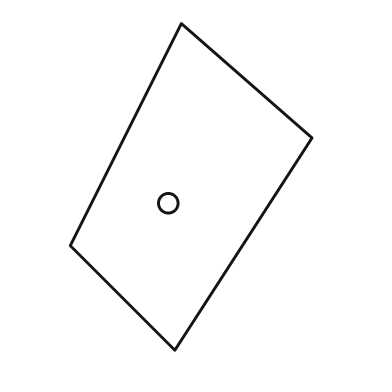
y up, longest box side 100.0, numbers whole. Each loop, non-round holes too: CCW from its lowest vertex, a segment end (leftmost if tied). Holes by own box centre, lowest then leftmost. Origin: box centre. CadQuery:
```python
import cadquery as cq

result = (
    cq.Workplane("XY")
    .moveTo(-5.0, -50.0)
    .lineTo(37.0, 15.0)
    .lineTo(-3.0, 50.0)
    .lineTo(-37.0, -18.0)
    .close()
    .moveTo(-7.0, -5.0)
    .circle(3.0)
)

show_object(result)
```